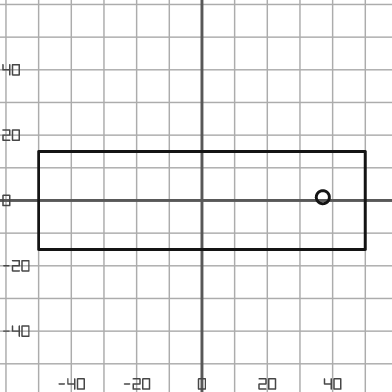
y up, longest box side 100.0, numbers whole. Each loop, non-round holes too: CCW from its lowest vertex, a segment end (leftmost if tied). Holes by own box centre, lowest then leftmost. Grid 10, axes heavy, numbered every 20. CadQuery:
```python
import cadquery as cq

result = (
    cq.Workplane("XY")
    .moveTo(-50.0, -15.0)
    .lineTo(50.0, -15.0)
    .lineTo(50.0, 15.0)
    .lineTo(-50.0, 15.0)
    .close()
    .moveTo(37.0, 1.0)
    .circle(2.0)
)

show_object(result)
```